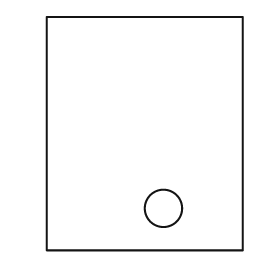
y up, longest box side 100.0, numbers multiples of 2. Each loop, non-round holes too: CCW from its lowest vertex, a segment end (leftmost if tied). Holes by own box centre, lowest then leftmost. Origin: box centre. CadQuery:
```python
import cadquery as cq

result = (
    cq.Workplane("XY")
    .moveTo(-42.0, -50.0)
    .lineTo(42.0, -50.0)
    .lineTo(42.0, 50.0)
    .lineTo(-42.0, 50.0)
    .close()
    .moveTo(8.0, -32.0)
    .circle(8.0)
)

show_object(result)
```